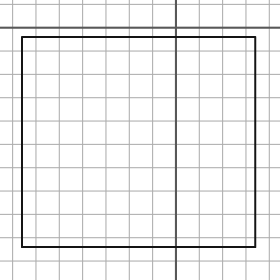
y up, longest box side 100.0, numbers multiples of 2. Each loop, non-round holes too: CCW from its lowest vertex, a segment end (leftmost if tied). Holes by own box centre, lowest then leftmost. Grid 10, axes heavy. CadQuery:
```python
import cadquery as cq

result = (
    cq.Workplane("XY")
    .moveTo(-66.0, -94.0)
    .lineTo(34.0, -94.0)
    .lineTo(34.0, -4.0)
    .lineTo(-66.0, -4.0)
    .close()
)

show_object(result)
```